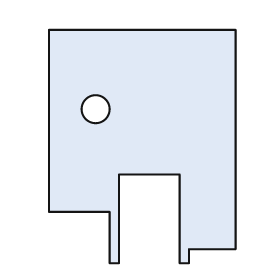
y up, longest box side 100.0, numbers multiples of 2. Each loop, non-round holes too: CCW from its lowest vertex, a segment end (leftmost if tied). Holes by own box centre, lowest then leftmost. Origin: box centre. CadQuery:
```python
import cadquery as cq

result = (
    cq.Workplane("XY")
    .moveTo(-14.0, -50.0)
    .lineTo(-10.0, -50.0)
    .lineTo(-10.0, -12.0)
    .lineTo(16.0, -12.0)
    .lineTo(16.0, -50.0)
    .lineTo(20.0, -50.0)
    .lineTo(20.0, -44.0)
    .lineTo(40.0, -44.0)
    .lineTo(40.0, 50.0)
    .lineTo(-40.0, 50.0)
    .lineTo(-40.0, -28.0)
    .lineTo(-14.0, -28.0)
    .close()
    .moveTo(-20.0, 16.0)
    .circle(6.0)
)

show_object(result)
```